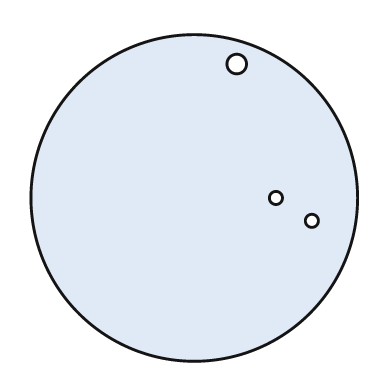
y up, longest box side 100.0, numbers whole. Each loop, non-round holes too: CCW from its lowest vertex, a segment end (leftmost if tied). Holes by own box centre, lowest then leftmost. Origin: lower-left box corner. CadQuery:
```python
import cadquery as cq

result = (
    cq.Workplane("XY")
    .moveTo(50.0, 50.0)
    .circle(50.0)
    .moveTo(86.0, 43.0)
    .circle(2.0)
    .moveTo(75.0, 50.0)
    .circle(2.0)
    .moveTo(63.0, 91.0)
    .circle(3.0)
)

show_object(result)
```